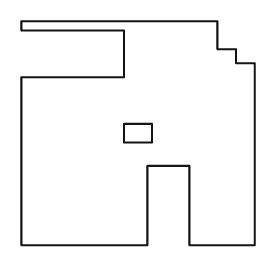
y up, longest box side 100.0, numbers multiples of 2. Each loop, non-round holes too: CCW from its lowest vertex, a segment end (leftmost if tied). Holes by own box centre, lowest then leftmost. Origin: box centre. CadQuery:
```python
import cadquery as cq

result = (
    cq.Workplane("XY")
    .moveTo(-50.0, -48.0)
    .lineTo(4.0, -48.0)
    .lineTo(4.0, -14.0)
    .lineTo(22.0, -14.0)
    .lineTo(22.0, -48.0)
    .lineTo(50.0, -48.0)
    .lineTo(50.0, 30.0)
    .lineTo(42.0, 30.0)
    .lineTo(42.0, 36.0)
    .lineTo(34.0, 36.0)
    .lineTo(34.0, 48.0)
    .lineTo(-50.0, 48.0)
    .lineTo(-50.0, 44.0)
    .lineTo(-6.0, 44.0)
    .lineTo(-6.0, 24.0)
    .lineTo(-50.0, 24.0)
    .close()
    .moveTo(-6.0, -4.0)
    .lineTo(6.0, -4.0)
    .lineTo(6.0, 4.0)
    .lineTo(-6.0, 4.0)
    .close()
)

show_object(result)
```